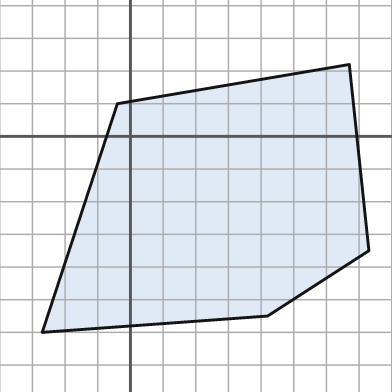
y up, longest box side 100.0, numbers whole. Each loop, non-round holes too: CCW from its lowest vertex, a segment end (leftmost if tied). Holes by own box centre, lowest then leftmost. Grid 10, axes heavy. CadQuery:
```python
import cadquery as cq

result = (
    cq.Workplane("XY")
    .moveTo(-27.0, -60.0)
    .lineTo(42.0, -55.0)
    .lineTo(73.0, -35.0)
    .lineTo(67.0, 22.0)
    .lineTo(-4.0, 10.0)
    .close()
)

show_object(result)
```